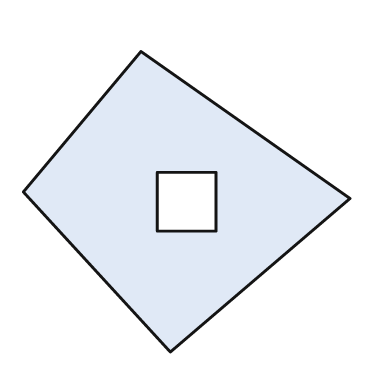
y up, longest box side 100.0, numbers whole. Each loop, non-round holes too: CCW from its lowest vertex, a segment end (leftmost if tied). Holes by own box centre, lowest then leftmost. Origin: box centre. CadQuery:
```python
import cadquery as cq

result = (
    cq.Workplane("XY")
    .moveTo(-5.0, -46.0)
    .lineTo(50.0, 1.0)
    .lineTo(-14.0, 46.0)
    .lineTo(-50.0, 3.0)
    .close()
    .moveTo(-9.0, -9.0)
    .lineTo(9.0, -9.0)
    .lineTo(9.0, 9.0)
    .lineTo(-9.0, 9.0)
    .close()
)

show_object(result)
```